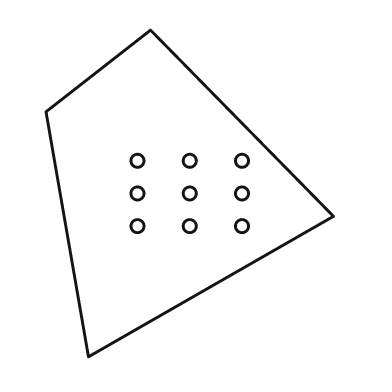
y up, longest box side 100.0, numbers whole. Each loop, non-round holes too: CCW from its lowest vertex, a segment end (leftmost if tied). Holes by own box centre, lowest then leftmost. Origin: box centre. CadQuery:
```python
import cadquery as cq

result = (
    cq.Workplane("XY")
    .moveTo(-31.0, -50.0)
    .lineTo(44.0, -7.0)
    .lineTo(-12.0, 50.0)
    .lineTo(-44.0, 25.0)
    .close()
    .moveTo(-16.0, -10.0)
    .circle(2.0)
    .moveTo(0.0, -10.0)
    .circle(2.0)
    .moveTo(16.0, -10.0)
    .circle(2.0)
    .moveTo(-16.0, 0.0)
    .circle(2.0)
    .moveTo(0.0, 0.0)
    .circle(2.0)
    .moveTo(16.0, 0.0)
    .circle(2.0)
    .moveTo(-16.0, 10.0)
    .circle(2.0)
    .moveTo(0.0, 10.0)
    .circle(2.0)
    .moveTo(16.0, 10.0)
    .circle(2.0)
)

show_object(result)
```